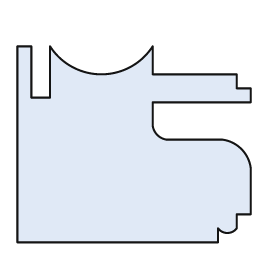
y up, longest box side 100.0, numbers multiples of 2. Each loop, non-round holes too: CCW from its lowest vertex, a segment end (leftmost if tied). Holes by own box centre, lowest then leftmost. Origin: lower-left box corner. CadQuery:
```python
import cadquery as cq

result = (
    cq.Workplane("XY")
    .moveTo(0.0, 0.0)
    .lineTo(86.0, 0.0)
    .lineTo(86.0, 6.0)
    .threePointArc((90.0, 4.0), (94.0, 6.0))
    .lineTo(94.0, 12.0)
    .lineTo(100.0, 12.0)
    .lineTo(100.0, 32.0)
    .threePointArc((96.0, 40.0), (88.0, 44.0))
    .lineTo(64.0, 44.0)
    .threePointArc((60.0, 46.0), (58.0, 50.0))
    .lineTo(58.0, 60.0)
    .lineTo(100.0, 60.0)
    .lineTo(100.0, 66.0)
    .lineTo(94.0, 66.0)
    .lineTo(94.0, 72.0)
    .lineTo(58.0, 72.0)
    .lineTo(58.0, 84.0)
    .threePointArc((36.0, 72.0), (14.0, 84.0))
    .lineTo(14.0, 62.0)
    .lineTo(6.0, 62.0)
    .lineTo(6.0, 84.0)
    .lineTo(0.0, 84.0)
    .close()
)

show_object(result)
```